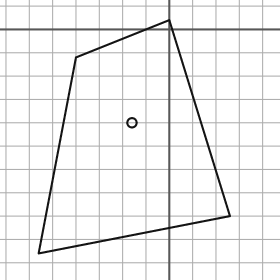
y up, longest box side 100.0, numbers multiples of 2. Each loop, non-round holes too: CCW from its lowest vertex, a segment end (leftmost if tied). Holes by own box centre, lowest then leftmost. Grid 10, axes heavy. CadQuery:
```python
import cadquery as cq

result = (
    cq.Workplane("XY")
    .moveTo(-56.0, -96.0)
    .lineTo(26.0, -80.0)
    .lineTo(0.0, 4.0)
    .lineTo(-40.0, -12.0)
    .close()
    .moveTo(-16.0, -40.0)
    .circle(2.0)
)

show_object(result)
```